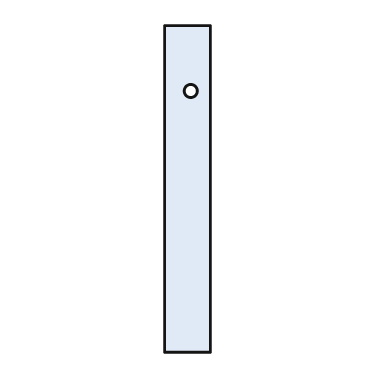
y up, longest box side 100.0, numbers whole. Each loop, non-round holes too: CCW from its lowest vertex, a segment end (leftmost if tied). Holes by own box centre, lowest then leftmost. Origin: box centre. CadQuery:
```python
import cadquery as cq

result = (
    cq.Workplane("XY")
    .moveTo(-7.0, -50.0)
    .lineTo(7.0, -50.0)
    .lineTo(7.0, 50.0)
    .lineTo(-7.0, 50.0)
    .close()
    .moveTo(1.0, 30.0)
    .circle(2.0)
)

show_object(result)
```